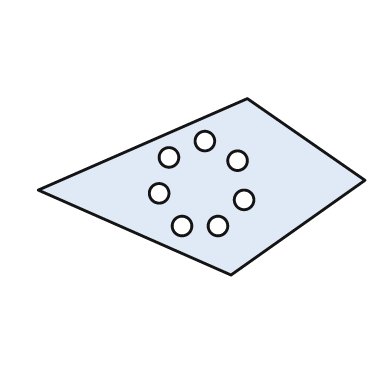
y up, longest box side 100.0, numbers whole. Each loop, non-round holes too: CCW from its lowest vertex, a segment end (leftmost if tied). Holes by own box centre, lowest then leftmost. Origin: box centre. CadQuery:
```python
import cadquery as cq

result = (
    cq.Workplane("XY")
    .moveTo(9.0, -27.0)
    .lineTo(50.0, 2.0)
    .lineTo(14.0, 27.0)
    .lineTo(-50.0, -1.0)
    .close()
    .moveTo(-6.0, -12.0)
    .circle(3.0)
    .moveTo(5.0, -12.0)
    .circle(3.0)
    .moveTo(13.0, -4.0)
    .circle(3.0)
    .moveTo(-13.0, -2.0)
    .circle(3.0)
    .moveTo(11.0, 8.0)
    .circle(3.0)
    .moveTo(-10.0, 9.0)
    .circle(3.0)
    .moveTo(1.0, 14.0)
    .circle(3.0)
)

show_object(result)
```